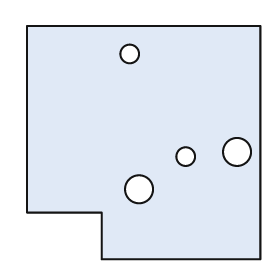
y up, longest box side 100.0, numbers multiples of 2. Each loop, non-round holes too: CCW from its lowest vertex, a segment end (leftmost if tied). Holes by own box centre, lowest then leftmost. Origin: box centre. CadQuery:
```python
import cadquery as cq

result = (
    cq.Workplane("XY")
    .moveTo(-18.0, -50.0)
    .lineTo(50.0, -50.0)
    .lineTo(50.0, 50.0)
    .lineTo(-50.0, 50.0)
    .lineTo(-50.0, -30.0)
    .lineTo(-18.0, -30.0)
    .close()
    .moveTo(-2.0, -20.0)
    .circle(6.0)
    .moveTo(18.0, -6.0)
    .circle(4.0)
    .moveTo(40.0, -4.0)
    .circle(6.0)
    .moveTo(-6.0, 38.0)
    .circle(4.0)
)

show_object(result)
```